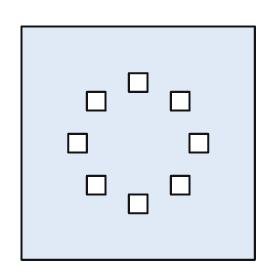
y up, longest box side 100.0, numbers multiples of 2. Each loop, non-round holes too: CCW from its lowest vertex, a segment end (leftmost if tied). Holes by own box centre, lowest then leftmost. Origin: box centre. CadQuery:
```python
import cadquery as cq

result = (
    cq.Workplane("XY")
    .moveTo(-50.0, -50.0)
    .lineTo(50.0, -50.0)
    .lineTo(50.0, 50.0)
    .lineTo(-50.0, 50.0)
    .close()
    .moveTo(-4.0, -30.0)
    .lineTo(4.0, -30.0)
    .lineTo(4.0, -22.0)
    .lineTo(-4.0, -22.0)
    .close()
    .moveTo(-22.0, -22.0)
    .lineTo(-14.0, -22.0)
    .lineTo(-14.0, -14.0)
    .lineTo(-22.0, -14.0)
    .close()
    .moveTo(14.0, -22.0)
    .lineTo(22.0, -22.0)
    .lineTo(22.0, -14.0)
    .lineTo(14.0, -14.0)
    .close()
    .moveTo(-30.0, -4.0)
    .lineTo(-22.0, -4.0)
    .lineTo(-22.0, 4.0)
    .lineTo(-30.0, 4.0)
    .close()
    .moveTo(22.0, -4.0)
    .lineTo(30.0, -4.0)
    .lineTo(30.0, 4.0)
    .lineTo(22.0, 4.0)
    .close()
    .moveTo(-22.0, 14.0)
    .lineTo(-14.0, 14.0)
    .lineTo(-14.0, 22.0)
    .lineTo(-22.0, 22.0)
    .close()
    .moveTo(14.0, 14.0)
    .lineTo(22.0, 14.0)
    .lineTo(22.0, 22.0)
    .lineTo(14.0, 22.0)
    .close()
    .moveTo(-4.0, 22.0)
    .lineTo(4.0, 22.0)
    .lineTo(4.0, 30.0)
    .lineTo(-4.0, 30.0)
    .close()
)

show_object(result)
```